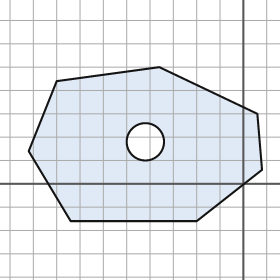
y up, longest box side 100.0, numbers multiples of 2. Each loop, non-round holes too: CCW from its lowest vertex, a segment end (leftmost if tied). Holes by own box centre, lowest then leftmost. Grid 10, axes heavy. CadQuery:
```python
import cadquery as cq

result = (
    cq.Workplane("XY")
    .moveTo(-74.0, -16.0)
    .lineTo(-20.0, -16.0)
    .lineTo(8.0, 6.0)
    .lineTo(6.0, 30.0)
    .lineTo(-36.0, 50.0)
    .lineTo(-80.0, 44.0)
    .lineTo(-92.0, 14.0)
    .close()
    .moveTo(-42.0, 18.0)
    .circle(8.0)
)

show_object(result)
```